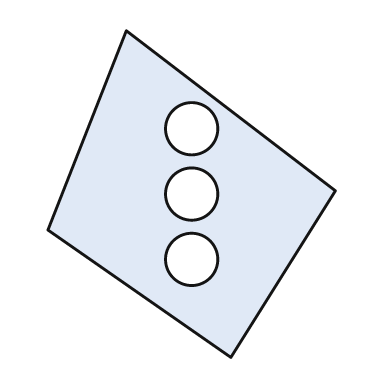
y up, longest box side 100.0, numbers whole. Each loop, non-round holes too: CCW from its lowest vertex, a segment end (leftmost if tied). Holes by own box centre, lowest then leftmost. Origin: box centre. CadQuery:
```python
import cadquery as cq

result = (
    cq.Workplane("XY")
    .moveTo(12.0, -50.0)
    .lineTo(44.0, 1.0)
    .lineTo(-20.0, 50.0)
    .lineTo(-44.0, -11.0)
    .close()
    .moveTo(0.0, -20.0)
    .circle(8.0)
    .moveTo(0.0, 0.0)
    .circle(8.0)
    .moveTo(0.0, 20.0)
    .circle(8.0)
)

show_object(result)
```